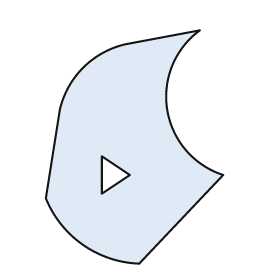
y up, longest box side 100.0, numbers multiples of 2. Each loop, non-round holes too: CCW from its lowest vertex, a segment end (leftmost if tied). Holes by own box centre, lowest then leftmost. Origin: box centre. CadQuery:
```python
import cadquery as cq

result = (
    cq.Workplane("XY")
    .moveTo(2.0, -50.0)
    .lineTo(38.0, -12.0)
    .threePointArc((14.0, 16.0), (28.0, 50.0))
    .lineTo(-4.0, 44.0)
    .threePointArc((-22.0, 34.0), (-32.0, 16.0))
    .lineTo(-38.0, -22.0)
    .threePointArc((-22.0, -42.0), (2.0, -50.0))
    .close()
    .moveTo(-14.0, -20.0)
    .lineTo(-2.0, -12.0)
    .lineTo(-14.0, -4.0)
    .close()
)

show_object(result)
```